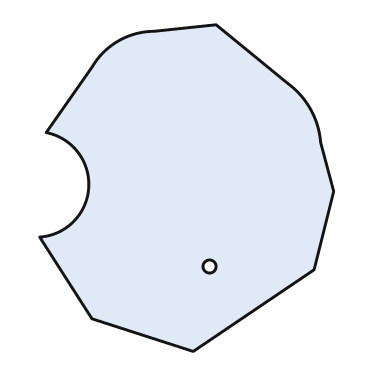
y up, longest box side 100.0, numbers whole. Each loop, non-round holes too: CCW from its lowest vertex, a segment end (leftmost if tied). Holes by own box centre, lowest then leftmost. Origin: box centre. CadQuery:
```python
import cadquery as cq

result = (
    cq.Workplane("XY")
    .moveTo(2.0, -50.0)
    .lineTo(39.0, -25.0)
    .lineTo(45.0, -1.0)
    .lineTo(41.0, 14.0)
    .threePointArc((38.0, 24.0), (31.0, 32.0))
    .lineTo(9.0, 50.0)
    .lineTo(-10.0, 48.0)
    .threePointArc((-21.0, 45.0), (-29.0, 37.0))
    .lineTo(-43.0, 17.0)
    .threePointArc((-30.0, 0.0), (-45.0, -15.0))
    .lineTo(-29.0, -40.0)
    .close()
    .moveTo(7.0, -24.0)
    .circle(2.0)
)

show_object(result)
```